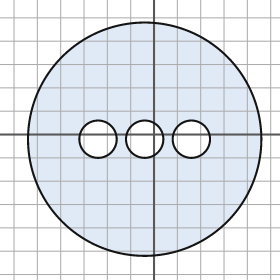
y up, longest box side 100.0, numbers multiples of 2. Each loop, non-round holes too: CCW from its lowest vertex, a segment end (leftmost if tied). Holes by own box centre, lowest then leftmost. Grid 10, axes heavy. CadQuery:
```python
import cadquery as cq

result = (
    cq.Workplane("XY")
    .moveTo(-4.0, -2.0)
    .circle(50.0)
    .moveTo(-24.0, -2.0)
    .circle(8.0)
    .moveTo(-4.0, -2.0)
    .circle(8.0)
    .moveTo(16.0, -2.0)
    .circle(8.0)
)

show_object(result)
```